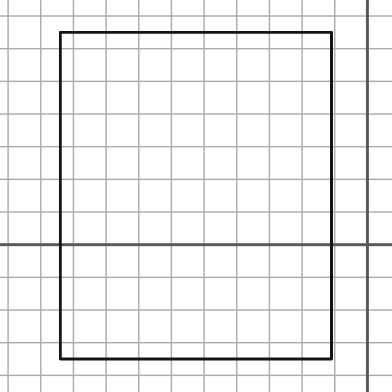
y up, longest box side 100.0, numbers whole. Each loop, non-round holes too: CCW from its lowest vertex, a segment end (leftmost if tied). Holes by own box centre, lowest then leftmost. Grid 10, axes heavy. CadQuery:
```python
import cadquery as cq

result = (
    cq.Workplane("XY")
    .moveTo(-94.0, -35.0)
    .lineTo(-11.0, -35.0)
    .lineTo(-11.0, 65.0)
    .lineTo(-94.0, 65.0)
    .close()
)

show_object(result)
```